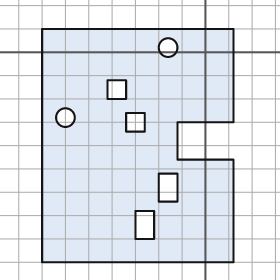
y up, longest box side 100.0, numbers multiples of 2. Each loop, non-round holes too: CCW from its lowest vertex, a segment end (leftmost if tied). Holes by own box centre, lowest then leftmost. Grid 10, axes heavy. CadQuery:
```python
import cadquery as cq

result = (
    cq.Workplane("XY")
    .moveTo(-70.0, -90.0)
    .lineTo(12.0, -90.0)
    .lineTo(12.0, -46.0)
    .lineTo(-12.0, -46.0)
    .lineTo(-12.0, -30.0)
    .lineTo(12.0, -30.0)
    .lineTo(12.0, 10.0)
    .lineTo(-70.0, 10.0)
    .close()
    .moveTo(-30.0, -80.0)
    .lineTo(-22.0, -80.0)
    .lineTo(-22.0, -68.0)
    .lineTo(-30.0, -68.0)
    .close()
    .moveTo(-20.0, -64.0)
    .lineTo(-12.0, -64.0)
    .lineTo(-12.0, -52.0)
    .lineTo(-20.0, -52.0)
    .close()
    .moveTo(-34.0, -34.0)
    .lineTo(-26.0, -34.0)
    .lineTo(-26.0, -26.0)
    .lineTo(-34.0, -26.0)
    .close()
    .moveTo(-60.0, -28.0)
    .circle(4.0)
    .moveTo(-42.0, -20.0)
    .lineTo(-34.0, -20.0)
    .lineTo(-34.0, -12.0)
    .lineTo(-42.0, -12.0)
    .close()
    .moveTo(-16.0, 2.0)
    .circle(4.0)
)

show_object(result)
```